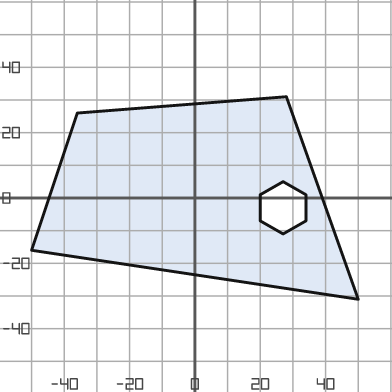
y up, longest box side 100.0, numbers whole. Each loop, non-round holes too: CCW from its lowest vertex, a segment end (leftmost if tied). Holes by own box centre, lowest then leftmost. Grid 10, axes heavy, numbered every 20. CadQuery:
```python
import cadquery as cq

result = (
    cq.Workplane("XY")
    .moveTo(50.0, -31.0)
    .lineTo(28.0, 31.0)
    .lineTo(-36.0, 26.0)
    .lineTo(-50.0, -16.0)
    .close()
    .moveTo(27.0, -11.0)
    .lineTo(34.0, -7.0)
    .lineTo(34.0, 1.0)
    .lineTo(27.0, 5.0)
    .lineTo(20.0, 1.0)
    .lineTo(20.0, -7.0)
    .close()
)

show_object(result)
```